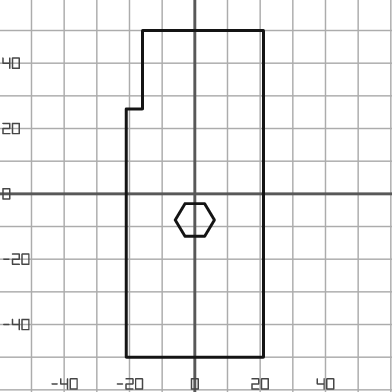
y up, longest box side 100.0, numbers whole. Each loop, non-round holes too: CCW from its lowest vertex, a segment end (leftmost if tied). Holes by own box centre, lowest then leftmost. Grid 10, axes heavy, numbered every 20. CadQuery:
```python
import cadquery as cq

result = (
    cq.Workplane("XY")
    .moveTo(-21.0, -50.0)
    .lineTo(21.0, -50.0)
    .lineTo(21.0, 50.0)
    .lineTo(-16.0, 50.0)
    .lineTo(-16.0, 26.0)
    .lineTo(-21.0, 26.0)
    .close()
    .moveTo(-3.0, -13.0)
    .lineTo(3.0, -13.0)
    .lineTo(6.0, -8.0)
    .lineTo(3.0, -3.0)
    .lineTo(-3.0, -3.0)
    .lineTo(-6.0, -8.0)
    .close()
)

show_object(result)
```